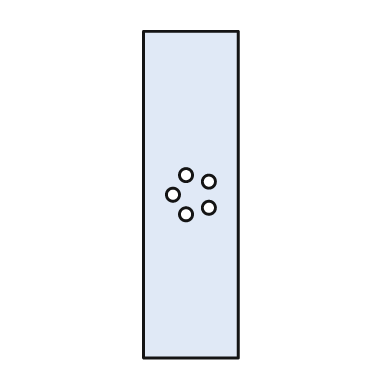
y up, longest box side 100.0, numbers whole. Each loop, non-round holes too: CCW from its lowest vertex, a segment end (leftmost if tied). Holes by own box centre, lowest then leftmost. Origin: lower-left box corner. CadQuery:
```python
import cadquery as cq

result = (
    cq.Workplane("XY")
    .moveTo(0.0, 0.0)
    .lineTo(29.0, 0.0)
    .lineTo(29.0, 100.0)
    .lineTo(0.0, 100.0)
    .close()
    .moveTo(13.0, 44.0)
    .circle(2.0)
    .moveTo(20.0, 46.0)
    .circle(2.0)
    .moveTo(9.0, 50.0)
    .circle(2.0)
    .moveTo(20.0, 54.0)
    .circle(2.0)
    .moveTo(13.0, 56.0)
    .circle(2.0)
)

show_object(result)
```